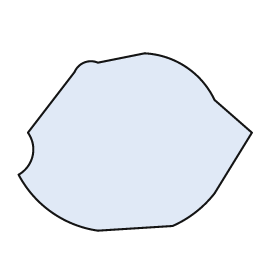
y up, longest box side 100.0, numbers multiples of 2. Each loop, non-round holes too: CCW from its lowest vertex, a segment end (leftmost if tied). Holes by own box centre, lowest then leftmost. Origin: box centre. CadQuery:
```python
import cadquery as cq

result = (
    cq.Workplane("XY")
    .moveTo(-16.0, -38.0)
    .lineTo(16.0, -36.0)
    .threePointArc((26.0, -30.0), (34.0, -22.0))
    .lineTo(50.0, 4.0)
    .lineTo(34.0, 18.0)
    .threePointArc((22.0, 32.0), (4.0, 38.0))
    .lineTo(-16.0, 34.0)
    .threePointArc((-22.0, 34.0), (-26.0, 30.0))
    .lineTo(-46.0, 4.0)
    .threePointArc((-44.0, -6.0), (-50.0, -14.0))
    .threePointArc((-36.0, -30.0), (-16.0, -38.0))
    .close()
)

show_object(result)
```